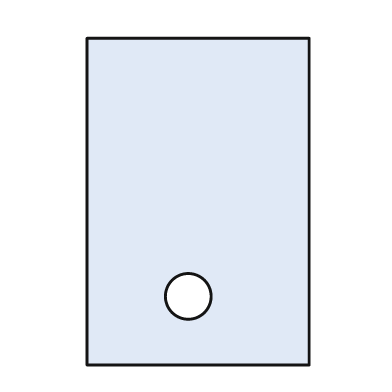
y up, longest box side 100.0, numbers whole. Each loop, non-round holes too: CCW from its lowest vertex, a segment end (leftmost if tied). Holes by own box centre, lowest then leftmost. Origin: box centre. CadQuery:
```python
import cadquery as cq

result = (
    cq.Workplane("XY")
    .moveTo(-34.0, -50.0)
    .lineTo(34.0, -50.0)
    .lineTo(34.0, 50.0)
    .lineTo(-34.0, 50.0)
    .close()
    .moveTo(-3.0, -29.0)
    .circle(7.0)
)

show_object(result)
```